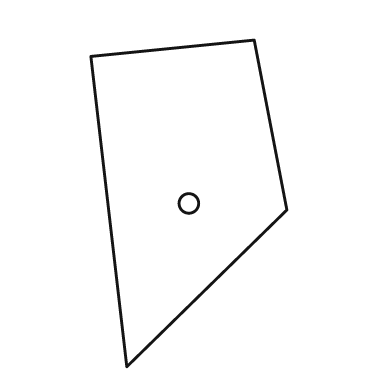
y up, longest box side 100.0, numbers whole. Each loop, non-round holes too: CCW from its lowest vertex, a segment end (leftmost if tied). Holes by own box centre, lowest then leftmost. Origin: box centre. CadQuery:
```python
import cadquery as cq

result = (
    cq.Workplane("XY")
    .moveTo(-19.0, -50.0)
    .lineTo(30.0, -2.0)
    .lineTo(20.0, 50.0)
    .lineTo(-30.0, 45.0)
    .close()
    .moveTo(0.0, 0.0)
    .circle(3.0)
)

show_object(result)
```